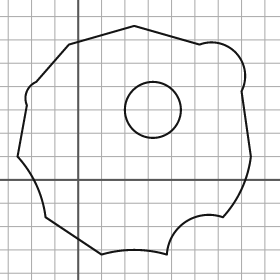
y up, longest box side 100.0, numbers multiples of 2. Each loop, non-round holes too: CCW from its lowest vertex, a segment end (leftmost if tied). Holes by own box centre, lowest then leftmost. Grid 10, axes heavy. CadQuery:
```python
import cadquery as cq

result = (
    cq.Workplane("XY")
    .moveTo(10.0, -32.0)
    .threePointArc((24.0, -30.0), (38.0, -32.0))
    .threePointArc((46.0, -18.0), (62.0, -16.0))
    .threePointArc((70.0, -4.0), (74.0, 10.0))
    .lineTo(70.0, 38.0)
    .threePointArc((68.0, 54.0), (52.0, 58.0))
    .lineTo(24.0, 66.0)
    .lineTo(-4.0, 58.0)
    .lineTo(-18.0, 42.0)
    .threePointArc((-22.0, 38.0), (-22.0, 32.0))
    .lineTo(-26.0, 10.0)
    .threePointArc((-18.0, -2.0), (-14.0, -16.0))
    .close()
    .moveTo(32.0, 30.0)
    .circle(12.0)
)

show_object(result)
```